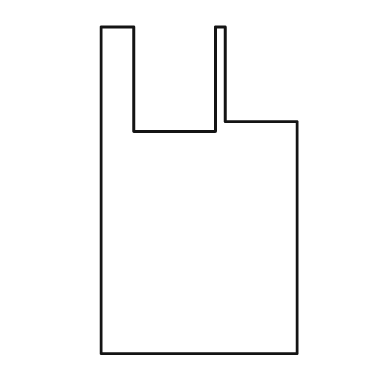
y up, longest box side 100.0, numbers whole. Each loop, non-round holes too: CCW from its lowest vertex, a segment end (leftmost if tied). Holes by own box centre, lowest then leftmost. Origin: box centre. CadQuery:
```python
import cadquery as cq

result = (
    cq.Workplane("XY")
    .moveTo(-30.0, -50.0)
    .lineTo(30.0, -50.0)
    .lineTo(30.0, 21.0)
    .lineTo(8.0, 21.0)
    .lineTo(8.0, 50.0)
    .lineTo(5.0, 50.0)
    .lineTo(5.0, 18.0)
    .lineTo(-20.0, 18.0)
    .lineTo(-20.0, 50.0)
    .lineTo(-30.0, 50.0)
    .close()
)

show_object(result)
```